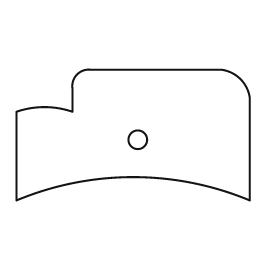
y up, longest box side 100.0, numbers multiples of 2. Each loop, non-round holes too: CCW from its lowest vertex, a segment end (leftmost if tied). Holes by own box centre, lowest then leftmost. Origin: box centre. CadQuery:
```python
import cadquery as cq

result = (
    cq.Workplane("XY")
    .moveTo(-50.0, -28.0)
    .threePointArc((0.0, -18.0), (50.0, -28.0))
    .lineTo(50.0, 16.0)
    .threePointArc((46.0, 24.0), (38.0, 28.0))
    .lineTo(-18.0, 28.0)
    .threePointArc((-24.0, 26.0), (-26.0, 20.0))
    .lineTo(-26.0, 10.0)
    .threePointArc((-38.0, 12.0), (-50.0, 10.0))
    .close()
    .moveTo(2.0, -2.0)
    .circle(4.0)
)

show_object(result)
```